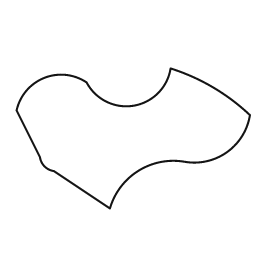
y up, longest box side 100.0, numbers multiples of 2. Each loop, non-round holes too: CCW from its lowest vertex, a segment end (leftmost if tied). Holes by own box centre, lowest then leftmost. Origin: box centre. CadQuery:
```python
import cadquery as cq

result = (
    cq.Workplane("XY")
    .moveTo(-10.0, -30.0)
    .threePointArc((2.0, -14.0), (22.0, -10.0))
    .threePointArc((40.0, -6.0), (50.0, 10.0))
    .threePointArc((34.0, 22.0), (16.0, 30.0))
    .threePointArc((0.0, 14.0), (-20.0, 24.0))
    .threePointArc((-38.0, 26.0), (-50.0, 12.0))
    .lineTo(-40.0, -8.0)
    .threePointArc((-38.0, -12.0), (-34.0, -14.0))
    .close()
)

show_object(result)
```